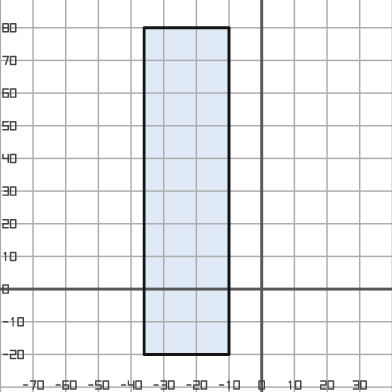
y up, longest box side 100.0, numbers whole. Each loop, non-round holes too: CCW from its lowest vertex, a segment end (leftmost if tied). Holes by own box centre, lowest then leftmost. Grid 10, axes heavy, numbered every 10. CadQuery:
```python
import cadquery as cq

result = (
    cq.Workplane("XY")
    .moveTo(-36.0, -20.0)
    .lineTo(-10.0, -20.0)
    .lineTo(-10.0, 80.0)
    .lineTo(-36.0, 80.0)
    .close()
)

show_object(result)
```